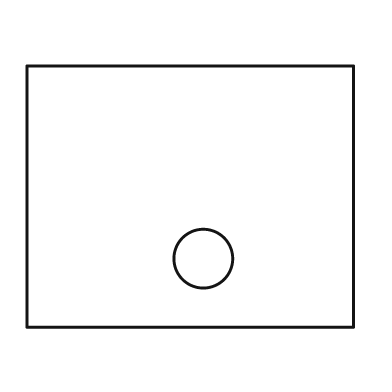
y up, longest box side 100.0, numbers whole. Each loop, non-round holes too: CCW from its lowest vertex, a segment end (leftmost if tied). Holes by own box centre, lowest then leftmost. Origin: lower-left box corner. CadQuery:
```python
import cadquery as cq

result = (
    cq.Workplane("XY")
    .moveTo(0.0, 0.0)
    .lineTo(100.0, 0.0)
    .lineTo(100.0, 80.0)
    .lineTo(0.0, 80.0)
    .close()
    .moveTo(54.0, 21.0)
    .circle(9.0)
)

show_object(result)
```